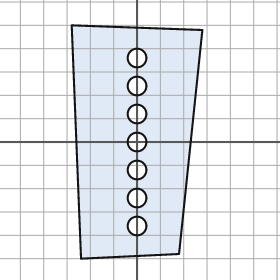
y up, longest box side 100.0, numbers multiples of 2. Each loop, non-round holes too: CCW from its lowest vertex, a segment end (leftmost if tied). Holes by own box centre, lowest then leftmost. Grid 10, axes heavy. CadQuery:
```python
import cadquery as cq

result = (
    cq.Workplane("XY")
    .moveTo(-24.0, -50.0)
    .lineTo(18.0, -48.0)
    .lineTo(28.0, 48.0)
    .lineTo(-28.0, 50.0)
    .close()
    .moveTo(0.0, -36.0)
    .circle(4.0)
    .moveTo(0.0, -24.0)
    .circle(4.0)
    .moveTo(0.0, -12.0)
    .circle(4.0)
    .moveTo(0.0, 0.0)
    .circle(4.0)
    .moveTo(0.0, 12.0)
    .circle(4.0)
    .moveTo(0.0, 24.0)
    .circle(4.0)
    .moveTo(0.0, 36.0)
    .circle(4.0)
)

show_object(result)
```